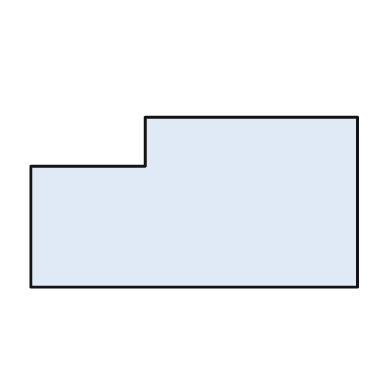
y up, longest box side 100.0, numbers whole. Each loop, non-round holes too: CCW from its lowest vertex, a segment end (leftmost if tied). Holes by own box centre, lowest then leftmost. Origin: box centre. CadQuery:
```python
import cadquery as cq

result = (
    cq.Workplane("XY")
    .moveTo(-50.0, -26.0)
    .lineTo(50.0, -26.0)
    .lineTo(50.0, 26.0)
    .lineTo(-15.0, 26.0)
    .lineTo(-15.0, 11.0)
    .lineTo(-50.0, 11.0)
    .close()
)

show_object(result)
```